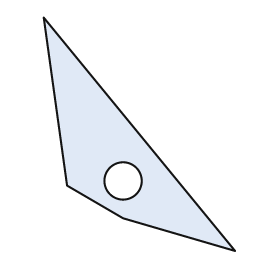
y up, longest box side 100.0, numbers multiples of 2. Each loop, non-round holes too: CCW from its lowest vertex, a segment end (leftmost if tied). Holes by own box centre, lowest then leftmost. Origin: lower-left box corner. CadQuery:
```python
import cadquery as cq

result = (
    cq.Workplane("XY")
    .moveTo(82.0, 0.0)
    .lineTo(0.0, 100.0)
    .lineTo(10.0, 28.0)
    .lineTo(34.0, 14.0)
    .close()
    .moveTo(34.0, 30.0)
    .circle(8.0)
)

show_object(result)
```